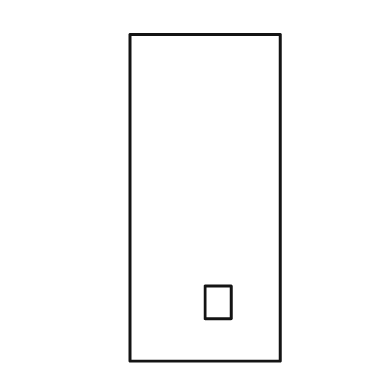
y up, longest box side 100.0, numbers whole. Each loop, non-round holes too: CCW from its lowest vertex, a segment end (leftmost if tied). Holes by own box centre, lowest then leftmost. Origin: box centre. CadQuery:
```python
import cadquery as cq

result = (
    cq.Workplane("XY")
    .moveTo(-23.0, -50.0)
    .lineTo(23.0, -50.0)
    .lineTo(23.0, 50.0)
    .lineTo(-23.0, 50.0)
    .close()
    .moveTo(0.0, -37.0)
    .lineTo(8.0, -37.0)
    .lineTo(8.0, -27.0)
    .lineTo(0.0, -27.0)
    .close()
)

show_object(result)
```